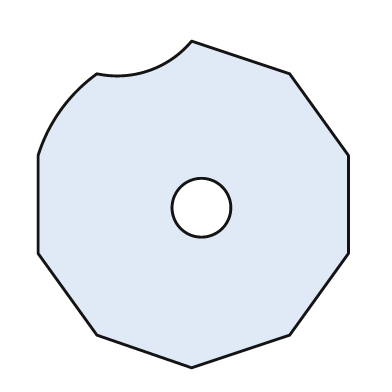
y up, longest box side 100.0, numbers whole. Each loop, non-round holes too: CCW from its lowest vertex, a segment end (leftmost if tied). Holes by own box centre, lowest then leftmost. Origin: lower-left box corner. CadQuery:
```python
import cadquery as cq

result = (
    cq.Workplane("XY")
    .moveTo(47.0, 0.0)
    .lineTo(77.0, 10.0)
    .lineTo(95.0, 35.0)
    .lineTo(95.0, 65.0)
    .lineTo(77.0, 90.0)
    .lineTo(47.0, 100.0)
    .threePointArc((34.0, 91.0), (18.0, 90.0))
    .threePointArc((7.0, 79.0), (0.0, 65.0))
    .lineTo(0.0, 35.0)
    .lineTo(18.0, 10.0)
    .close()
    .moveTo(50.0, 49.0)
    .circle(9.0)
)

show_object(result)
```